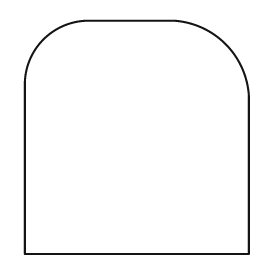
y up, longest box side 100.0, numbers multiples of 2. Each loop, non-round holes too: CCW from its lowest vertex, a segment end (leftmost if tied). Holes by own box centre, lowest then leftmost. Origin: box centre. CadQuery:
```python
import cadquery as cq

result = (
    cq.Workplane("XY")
    .moveTo(-48.0, -50.0)
    .lineTo(48.0, -50.0)
    .lineTo(48.0, 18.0)
    .threePointArc((38.0, 40.0), (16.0, 50.0))
    .lineTo(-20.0, 50.0)
    .threePointArc((-40.0, 42.0), (-48.0, 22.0))
    .close()
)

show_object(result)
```